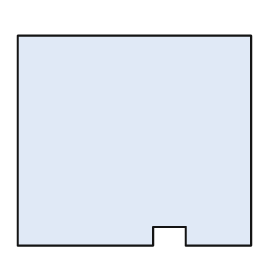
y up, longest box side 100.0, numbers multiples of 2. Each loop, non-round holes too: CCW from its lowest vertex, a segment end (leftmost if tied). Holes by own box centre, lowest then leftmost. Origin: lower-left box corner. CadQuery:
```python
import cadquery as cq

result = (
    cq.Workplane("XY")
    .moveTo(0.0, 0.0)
    .lineTo(58.0, 0.0)
    .lineTo(58.0, 8.0)
    .lineTo(72.0, 8.0)
    .lineTo(72.0, 0.0)
    .lineTo(100.0, 0.0)
    .lineTo(100.0, 90.0)
    .lineTo(0.0, 90.0)
    .close()
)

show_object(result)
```